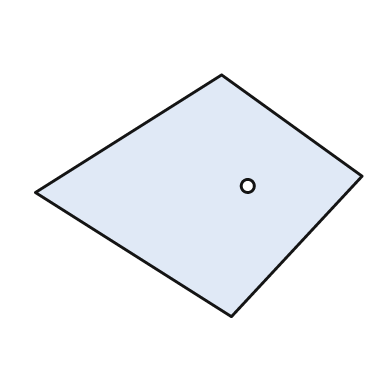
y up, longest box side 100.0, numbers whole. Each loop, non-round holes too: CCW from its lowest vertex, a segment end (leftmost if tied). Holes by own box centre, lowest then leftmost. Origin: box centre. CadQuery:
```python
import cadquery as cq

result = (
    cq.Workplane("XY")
    .moveTo(10.0, -37.0)
    .lineTo(50.0, 6.0)
    .lineTo(7.0, 37.0)
    .lineTo(-50.0, 1.0)
    .close()
    .moveTo(15.0, 3.0)
    .circle(2.0)
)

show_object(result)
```